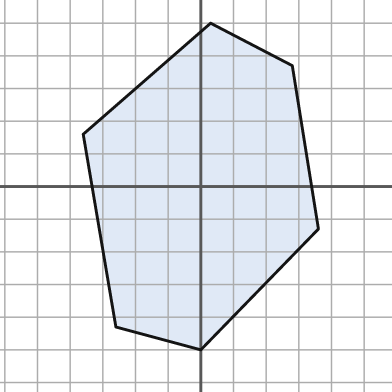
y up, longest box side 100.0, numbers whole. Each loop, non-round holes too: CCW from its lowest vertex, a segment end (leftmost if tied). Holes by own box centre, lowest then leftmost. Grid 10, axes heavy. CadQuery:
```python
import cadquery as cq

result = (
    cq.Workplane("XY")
    .moveTo(0.0, -50.0)
    .lineTo(36.0, -13.0)
    .lineTo(28.0, 37.0)
    .lineTo(3.0, 50.0)
    .lineTo(-36.0, 16.0)
    .lineTo(-26.0, -43.0)
    .close()
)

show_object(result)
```